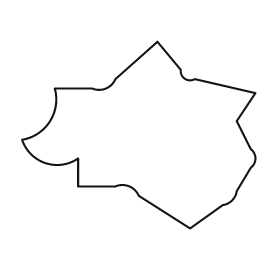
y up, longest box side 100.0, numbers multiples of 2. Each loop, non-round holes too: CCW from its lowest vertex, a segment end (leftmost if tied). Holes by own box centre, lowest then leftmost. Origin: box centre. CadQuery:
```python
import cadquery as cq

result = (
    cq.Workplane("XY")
    .moveTo(22.0, -40.0)
    .lineTo(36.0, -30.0)
    .threePointArc((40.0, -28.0), (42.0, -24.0))
    .lineTo(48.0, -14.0)
    .threePointArc((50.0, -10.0), (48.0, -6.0))
    .lineTo(42.0, 6.0)
    .lineTo(50.0, 18.0)
    .lineTo(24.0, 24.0)
    .threePointArc((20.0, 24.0), (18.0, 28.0))
    .lineTo(8.0, 40.0)
    .lineTo(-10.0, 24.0)
    .threePointArc((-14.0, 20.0), (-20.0, 20.0))
    .lineTo(-36.0, 20.0)
    .threePointArc((-38.0, 6.0), (-50.0, -2.0))
    .threePointArc((-40.0, -12.0), (-26.0, -10.0))
    .lineTo(-26.0, -22.0)
    .lineTo(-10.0, -22.0)
    .threePointArc((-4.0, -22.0), (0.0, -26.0))
    .close()
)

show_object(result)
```